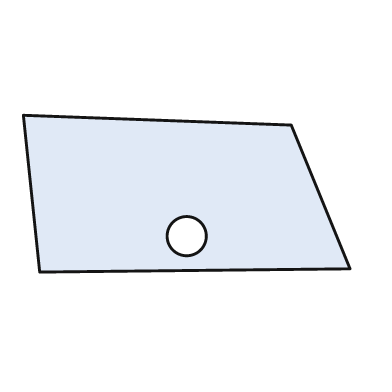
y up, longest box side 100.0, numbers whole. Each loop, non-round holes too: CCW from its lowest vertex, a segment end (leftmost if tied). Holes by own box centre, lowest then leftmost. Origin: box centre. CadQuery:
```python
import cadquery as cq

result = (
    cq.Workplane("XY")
    .moveTo(-45.0, -24.0)
    .lineTo(50.0, -23.0)
    .lineTo(32.0, 21.0)
    .lineTo(-50.0, 24.0)
    .close()
    .moveTo(0.0, -13.0)
    .circle(6.0)
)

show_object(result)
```